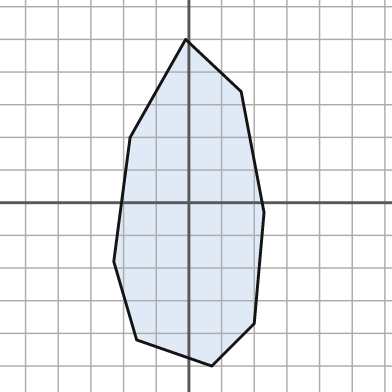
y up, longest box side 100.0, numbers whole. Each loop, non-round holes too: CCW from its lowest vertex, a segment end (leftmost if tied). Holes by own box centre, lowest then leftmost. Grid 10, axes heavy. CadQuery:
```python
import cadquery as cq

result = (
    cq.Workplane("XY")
    .moveTo(7.0, -50.0)
    .lineTo(20.0, -37.0)
    .lineTo(23.0, -3.0)
    .lineTo(16.0, 34.0)
    .lineTo(-1.0, 50.0)
    .lineTo(-18.0, 20.0)
    .lineTo(-23.0, -18.0)
    .lineTo(-16.0, -42.0)
    .close()
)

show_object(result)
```